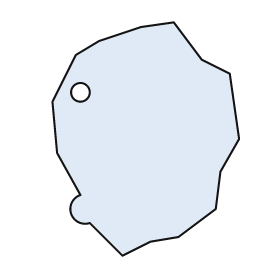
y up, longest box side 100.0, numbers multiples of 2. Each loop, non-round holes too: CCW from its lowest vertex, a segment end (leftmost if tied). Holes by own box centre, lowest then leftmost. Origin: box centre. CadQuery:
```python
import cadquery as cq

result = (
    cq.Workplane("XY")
    .moveTo(-10.0, -50.0)
    .lineTo(2.0, -44.0)
    .lineTo(14.0, -42.0)
    .lineTo(30.0, -30.0)
    .lineTo(32.0, -14.0)
    .lineTo(40.0, 0.0)
    .lineTo(36.0, 28.0)
    .lineTo(24.0, 34.0)
    .lineTo(12.0, 50.0)
    .lineTo(-2.0, 48.0)
    .lineTo(-20.0, 42.0)
    .lineTo(-30.0, 36.0)
    .lineTo(-40.0, 16.0)
    .lineTo(-38.0, -6.0)
    .lineTo(-28.0, -24.0)
    .threePointArc((-32.0, -32.0), (-24.0, -36.0))
    .close()
    .moveTo(-28.0, 20.0)
    .circle(4.0)
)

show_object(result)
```